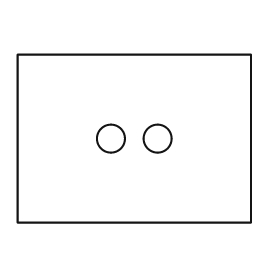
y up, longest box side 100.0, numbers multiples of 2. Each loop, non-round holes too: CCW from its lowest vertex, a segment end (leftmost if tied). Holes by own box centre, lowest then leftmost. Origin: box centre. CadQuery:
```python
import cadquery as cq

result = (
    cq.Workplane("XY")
    .moveTo(-50.0, -36.0)
    .lineTo(50.0, -36.0)
    .lineTo(50.0, 36.0)
    .lineTo(-50.0, 36.0)
    .close()
    .moveTo(-10.0, 0.0)
    .circle(6.0)
    .moveTo(10.0, 0.0)
    .circle(6.0)
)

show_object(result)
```